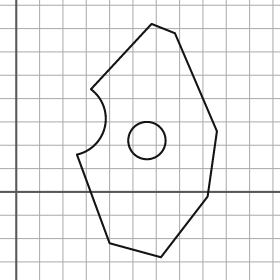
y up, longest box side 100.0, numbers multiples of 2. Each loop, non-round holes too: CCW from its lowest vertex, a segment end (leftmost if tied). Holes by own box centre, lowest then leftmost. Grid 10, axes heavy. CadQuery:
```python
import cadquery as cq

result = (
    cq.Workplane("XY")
    .moveTo(62.0, -28.0)
    .lineTo(82.0, -2.0)
    .lineTo(86.0, 26.0)
    .lineTo(68.0, 68.0)
    .lineTo(58.0, 72.0)
    .lineTo(32.0, 44.0)
    .threePointArc((38.0, 28.0), (26.0, 16.0))
    .lineTo(40.0, -22.0)
    .close()
    .moveTo(56.0, 22.0)
    .circle(8.0)
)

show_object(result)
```